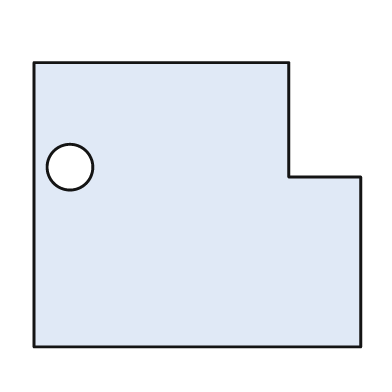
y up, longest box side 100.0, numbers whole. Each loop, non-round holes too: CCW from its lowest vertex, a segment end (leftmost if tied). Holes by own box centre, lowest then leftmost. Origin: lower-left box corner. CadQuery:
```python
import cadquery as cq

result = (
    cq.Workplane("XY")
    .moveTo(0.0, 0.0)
    .lineTo(100.0, 0.0)
    .lineTo(100.0, 52.0)
    .lineTo(78.0, 52.0)
    .lineTo(78.0, 87.0)
    .lineTo(0.0, 87.0)
    .close()
    .moveTo(11.0, 55.0)
    .circle(7.0)
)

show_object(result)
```